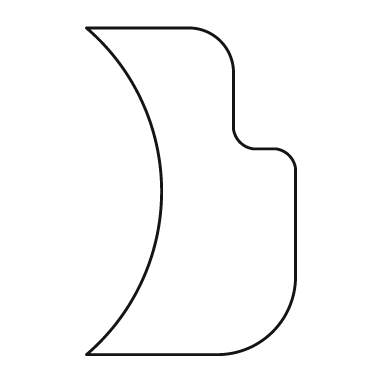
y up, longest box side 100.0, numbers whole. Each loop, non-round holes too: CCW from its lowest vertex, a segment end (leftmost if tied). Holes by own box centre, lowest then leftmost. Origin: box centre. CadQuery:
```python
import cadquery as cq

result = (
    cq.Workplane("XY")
    .moveTo(-32.0, -50.0)
    .lineTo(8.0, -50.0)
    .threePointArc((25.0, -43.0), (32.0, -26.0))
    .lineTo(32.0, 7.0)
    .threePointArc((30.0, 11.0), (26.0, 13.0))
    .lineTo(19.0, 13.0)
    .threePointArc((15.0, 15.0), (13.0, 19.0))
    .lineTo(13.0, 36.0)
    .threePointArc((9.0, 46.0), (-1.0, 50.0))
    .lineTo(-32.0, 50.0)
    .threePointArc((-9.0, 0.0), (-32.0, -50.0))
    .close()
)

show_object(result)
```